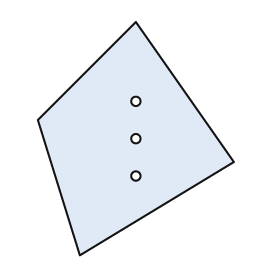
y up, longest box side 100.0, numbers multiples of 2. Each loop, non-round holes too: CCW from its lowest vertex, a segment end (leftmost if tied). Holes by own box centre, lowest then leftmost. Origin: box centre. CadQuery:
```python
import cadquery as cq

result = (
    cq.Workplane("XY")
    .moveTo(-24.0, -50.0)
    .lineTo(42.0, -10.0)
    .lineTo(0.0, 50.0)
    .lineTo(-42.0, 8.0)
    .close()
    .moveTo(0.0, -16.0)
    .circle(2.0)
    .moveTo(0.0, 0.0)
    .circle(2.0)
    .moveTo(0.0, 16.0)
    .circle(2.0)
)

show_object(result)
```